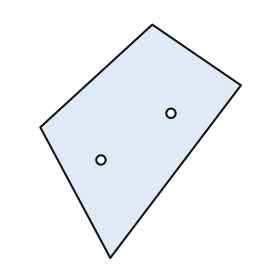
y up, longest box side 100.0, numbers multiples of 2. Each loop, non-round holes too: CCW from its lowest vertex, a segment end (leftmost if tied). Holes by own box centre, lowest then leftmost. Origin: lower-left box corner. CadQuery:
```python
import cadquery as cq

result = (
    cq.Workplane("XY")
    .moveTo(30.0, 0.0)
    .lineTo(86.0, 74.0)
    .lineTo(48.0, 100.0)
    .lineTo(0.0, 56.0)
    .close()
    .moveTo(26.0, 42.0)
    .circle(2.0)
    .moveTo(56.0, 62.0)
    .circle(2.0)
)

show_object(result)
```